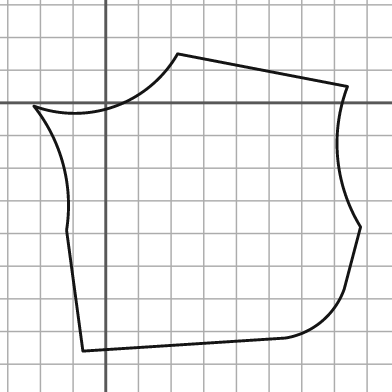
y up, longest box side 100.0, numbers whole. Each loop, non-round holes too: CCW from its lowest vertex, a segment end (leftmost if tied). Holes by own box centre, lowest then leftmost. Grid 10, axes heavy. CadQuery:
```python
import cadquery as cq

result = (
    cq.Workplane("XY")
    .moveTo(-7.0, -76.0)
    .lineTo(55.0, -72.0)
    .threePointArc((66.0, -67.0), (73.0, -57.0))
    .lineTo(78.0, -38.0)
    .threePointArc((71.0, -17.0), (74.0, 5.0))
    .lineTo(22.0, 15.0)
    .threePointArc((3.0, -1.0), (-22.0, -1.0))
    .threePointArc((-13.0, -19.0), (-12.0, -39.0))
    .close()
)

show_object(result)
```